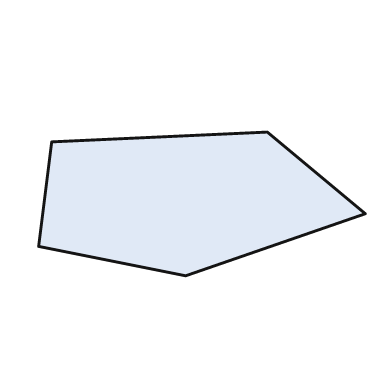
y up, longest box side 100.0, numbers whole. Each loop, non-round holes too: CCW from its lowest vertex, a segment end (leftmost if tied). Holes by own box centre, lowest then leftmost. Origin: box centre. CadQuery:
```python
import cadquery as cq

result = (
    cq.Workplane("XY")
    .moveTo(-5.0, -22.0)
    .lineTo(50.0, -3.0)
    .lineTo(20.0, 22.0)
    .lineTo(-46.0, 19.0)
    .lineTo(-50.0, -13.0)
    .close()
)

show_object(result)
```